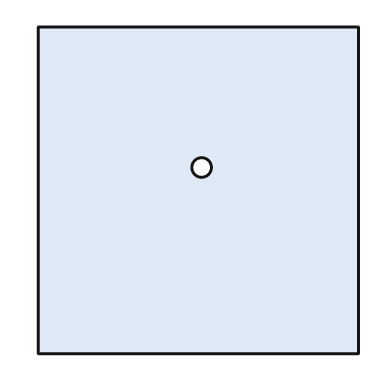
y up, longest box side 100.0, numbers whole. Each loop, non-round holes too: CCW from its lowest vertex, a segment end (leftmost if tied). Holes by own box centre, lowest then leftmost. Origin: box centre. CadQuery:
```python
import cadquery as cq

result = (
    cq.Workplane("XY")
    .moveTo(-49.0, -50.0)
    .lineTo(49.0, -50.0)
    .lineTo(49.0, 50.0)
    .lineTo(-49.0, 50.0)
    .close()
    .moveTo(1.0, 7.0)
    .circle(3.0)
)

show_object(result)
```